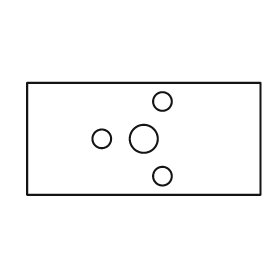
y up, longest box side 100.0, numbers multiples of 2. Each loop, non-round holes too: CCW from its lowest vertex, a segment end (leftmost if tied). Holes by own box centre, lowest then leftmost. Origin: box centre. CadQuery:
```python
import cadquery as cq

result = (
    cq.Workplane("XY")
    .moveTo(-50.0, -24.0)
    .lineTo(50.0, -24.0)
    .lineTo(50.0, 24.0)
    .lineTo(-50.0, 24.0)
    .close()
    .moveTo(8.0, -16.0)
    .circle(4.0)
    .moveTo(-18.0, 0.0)
    .circle(4.0)
    .moveTo(0.0, 0.0)
    .circle(6.0)
    .moveTo(8.0, 16.0)
    .circle(4.0)
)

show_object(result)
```